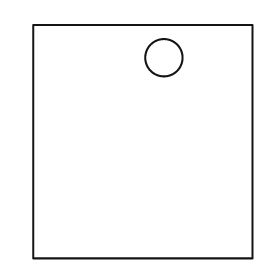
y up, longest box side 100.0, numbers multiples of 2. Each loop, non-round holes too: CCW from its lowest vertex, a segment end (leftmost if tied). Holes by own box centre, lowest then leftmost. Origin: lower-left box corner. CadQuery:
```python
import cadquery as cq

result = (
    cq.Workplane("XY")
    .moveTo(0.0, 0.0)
    .lineTo(94.0, 0.0)
    .lineTo(94.0, 100.0)
    .lineTo(0.0, 100.0)
    .close()
    .moveTo(56.0, 86.0)
    .circle(8.0)
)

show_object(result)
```